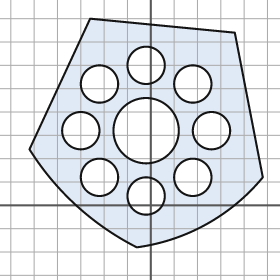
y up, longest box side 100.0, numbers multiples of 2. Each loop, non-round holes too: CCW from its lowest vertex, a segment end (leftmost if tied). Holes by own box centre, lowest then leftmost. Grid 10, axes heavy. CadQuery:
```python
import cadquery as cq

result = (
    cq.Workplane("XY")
    .moveTo(-6.0, -18.0)
    .threePointArc((24.0, -8.0), (48.0, 12.0))
    .lineTo(36.0, 74.0)
    .lineTo(-26.0, 80.0)
    .lineTo(-52.0, 24.0)
    .threePointArc((-32.0, 0.0), (-6.0, -18.0))
    .close()
    .moveTo(-2.0, 4.0)
    .circle(8.0)
    .moveTo(-22.0, 12.0)
    .circle(8.0)
    .moveTo(18.0, 12.0)
    .circle(8.0)
    .moveTo(-30.0, 32.0)
    .circle(8.0)
    .moveTo(-2.0, 32.0)
    .circle(14.0)
    .moveTo(26.0, 32.0)
    .circle(8.0)
    .moveTo(-22.0, 52.0)
    .circle(8.0)
    .moveTo(18.0, 52.0)
    .circle(8.0)
    .moveTo(-2.0, 60.0)
    .circle(8.0)
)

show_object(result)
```